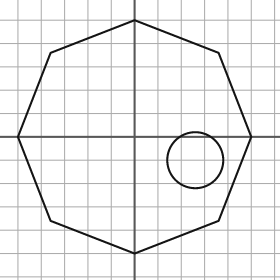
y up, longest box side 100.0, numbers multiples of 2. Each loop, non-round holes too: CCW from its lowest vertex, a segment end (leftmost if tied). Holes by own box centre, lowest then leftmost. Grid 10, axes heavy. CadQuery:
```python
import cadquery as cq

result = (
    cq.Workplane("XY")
    .moveTo(0.0, -50.0)
    .lineTo(36.0, -36.0)
    .lineTo(50.0, 0.0)
    .lineTo(36.0, 36.0)
    .lineTo(0.0, 50.0)
    .lineTo(-36.0, 36.0)
    .lineTo(-50.0, 0.0)
    .lineTo(-36.0, -36.0)
    .close()
    .moveTo(26.0, -10.0)
    .circle(12.0)
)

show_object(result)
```